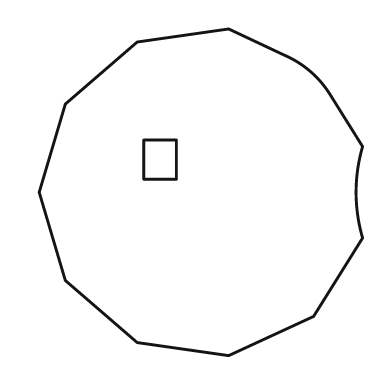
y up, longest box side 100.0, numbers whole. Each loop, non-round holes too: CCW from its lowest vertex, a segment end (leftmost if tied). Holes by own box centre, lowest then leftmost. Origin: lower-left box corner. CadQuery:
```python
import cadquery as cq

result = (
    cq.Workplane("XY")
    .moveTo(58.0, 0.0)
    .lineTo(84.0, 12.0)
    .lineTo(99.0, 36.0)
    .threePointArc((97.0, 50.0), (99.0, 64.0))
    .lineTo(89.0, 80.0)
    .threePointArc((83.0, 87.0), (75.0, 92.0))
    .lineTo(58.0, 100.0)
    .lineTo(30.0, 96.0)
    .lineTo(8.0, 77.0)
    .lineTo(0.0, 50.0)
    .lineTo(8.0, 23.0)
    .lineTo(30.0, 4.0)
    .close()
    .moveTo(32.0, 54.0)
    .lineTo(42.0, 54.0)
    .lineTo(42.0, 66.0)
    .lineTo(32.0, 66.0)
    .close()
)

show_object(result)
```